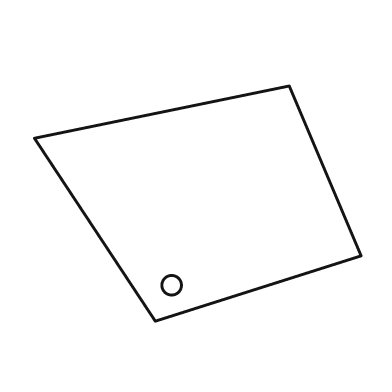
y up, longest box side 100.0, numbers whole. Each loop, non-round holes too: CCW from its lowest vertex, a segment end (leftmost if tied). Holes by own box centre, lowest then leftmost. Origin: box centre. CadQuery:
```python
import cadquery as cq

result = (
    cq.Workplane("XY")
    .moveTo(-13.0, -36.0)
    .lineTo(50.0, -16.0)
    .lineTo(28.0, 36.0)
    .lineTo(-50.0, 20.0)
    .close()
    .moveTo(-8.0, -25.0)
    .circle(3.0)
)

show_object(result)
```